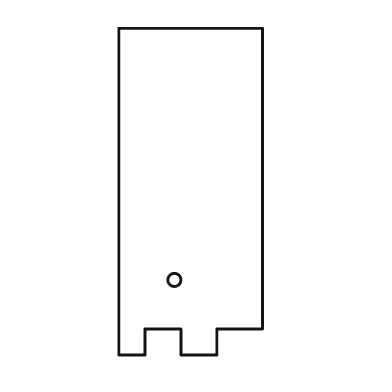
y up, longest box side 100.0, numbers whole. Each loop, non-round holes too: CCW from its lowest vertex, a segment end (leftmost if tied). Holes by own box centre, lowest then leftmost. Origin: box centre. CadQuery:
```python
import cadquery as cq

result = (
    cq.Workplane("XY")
    .moveTo(-22.0, -50.0)
    .lineTo(-14.0, -50.0)
    .lineTo(-14.0, -42.0)
    .lineTo(-3.0, -42.0)
    .lineTo(-3.0, -50.0)
    .lineTo(8.0, -50.0)
    .lineTo(8.0, -42.0)
    .lineTo(22.0, -42.0)
    .lineTo(22.0, 50.0)
    .lineTo(-22.0, 50.0)
    .close()
    .moveTo(-5.0, -27.0)
    .circle(2.0)
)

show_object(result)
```